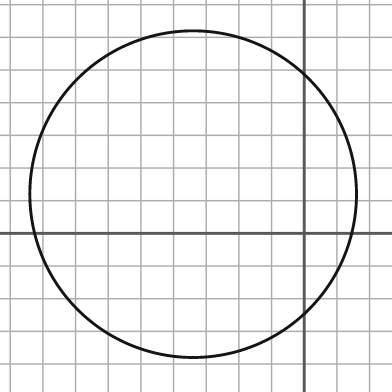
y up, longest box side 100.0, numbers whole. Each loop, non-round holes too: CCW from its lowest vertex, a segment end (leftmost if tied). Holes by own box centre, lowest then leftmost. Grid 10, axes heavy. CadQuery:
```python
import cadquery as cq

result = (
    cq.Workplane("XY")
    .moveTo(-34.0, 12.0)
    .circle(50.0)
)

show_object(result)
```